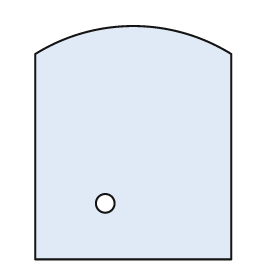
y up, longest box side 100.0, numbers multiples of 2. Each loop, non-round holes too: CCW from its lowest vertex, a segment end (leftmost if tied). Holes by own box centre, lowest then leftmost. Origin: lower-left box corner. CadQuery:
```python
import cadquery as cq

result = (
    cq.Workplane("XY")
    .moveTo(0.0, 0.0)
    .lineTo(84.0, 0.0)
    .lineTo(84.0, 88.0)
    .threePointArc((42.0, 100.0), (0.0, 88.0))
    .close()
    .moveTo(30.0, 24.0)
    .circle(4.0)
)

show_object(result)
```